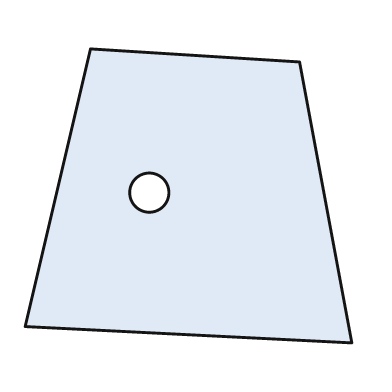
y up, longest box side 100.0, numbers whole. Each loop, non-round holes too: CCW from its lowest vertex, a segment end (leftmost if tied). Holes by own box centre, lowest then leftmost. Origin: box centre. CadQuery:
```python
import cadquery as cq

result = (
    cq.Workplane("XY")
    .moveTo(50.0, -45.0)
    .lineTo(34.0, 41.0)
    .lineTo(-30.0, 45.0)
    .lineTo(-50.0, -40.0)
    .close()
    .moveTo(-12.0, 1.0)
    .circle(6.0)
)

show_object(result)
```